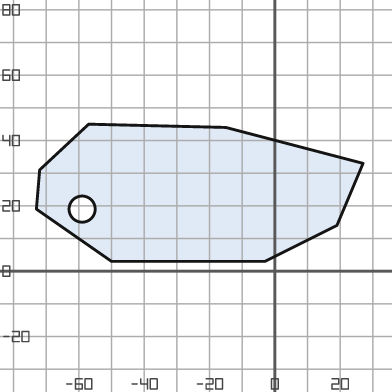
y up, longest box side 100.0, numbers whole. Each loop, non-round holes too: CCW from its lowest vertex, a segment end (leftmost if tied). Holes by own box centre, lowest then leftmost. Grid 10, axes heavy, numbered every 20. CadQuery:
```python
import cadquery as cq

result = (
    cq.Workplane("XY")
    .moveTo(-50.0, 3.0)
    .lineTo(-3.0, 3.0)
    .lineTo(19.0, 14.0)
    .lineTo(27.0, 33.0)
    .lineTo(-15.0, 44.0)
    .lineTo(-57.0, 45.0)
    .lineTo(-72.0, 31.0)
    .lineTo(-73.0, 19.0)
    .close()
    .moveTo(-59.0, 19.0)
    .circle(4.0)
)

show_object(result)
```